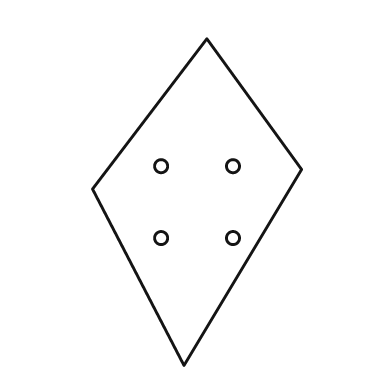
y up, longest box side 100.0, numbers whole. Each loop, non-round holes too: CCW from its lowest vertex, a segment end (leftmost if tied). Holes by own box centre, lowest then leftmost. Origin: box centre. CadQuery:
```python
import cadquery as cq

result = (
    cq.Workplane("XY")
    .moveTo(-4.0, -50.0)
    .lineTo(32.0, 10.0)
    .lineTo(3.0, 50.0)
    .lineTo(-32.0, 4.0)
    .close()
    .moveTo(-11.0, -11.0)
    .circle(2.0)
    .moveTo(11.0, -11.0)
    .circle(2.0)
    .moveTo(-11.0, 11.0)
    .circle(2.0)
    .moveTo(11.0, 11.0)
    .circle(2.0)
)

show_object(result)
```